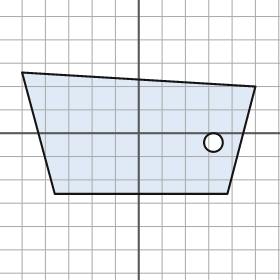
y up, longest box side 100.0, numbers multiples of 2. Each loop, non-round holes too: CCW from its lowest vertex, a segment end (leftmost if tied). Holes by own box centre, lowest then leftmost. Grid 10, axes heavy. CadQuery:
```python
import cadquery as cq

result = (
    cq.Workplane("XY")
    .moveTo(-36.0, -26.0)
    .lineTo(38.0, -26.0)
    .lineTo(50.0, 20.0)
    .lineTo(-50.0, 26.0)
    .close()
    .moveTo(32.0, -4.0)
    .circle(4.0)
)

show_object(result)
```